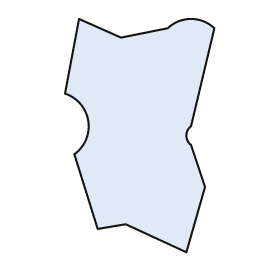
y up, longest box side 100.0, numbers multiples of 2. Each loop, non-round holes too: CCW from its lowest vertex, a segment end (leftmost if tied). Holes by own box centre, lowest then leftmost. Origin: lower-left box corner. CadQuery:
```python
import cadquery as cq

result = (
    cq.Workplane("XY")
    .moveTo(52.0, 0.0)
    .lineTo(60.0, 28.0)
    .lineTo(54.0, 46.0)
    .threePointArc((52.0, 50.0), (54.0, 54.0))
    .lineTo(64.0, 96.0)
    .threePointArc((54.0, 100.0), (44.0, 96.0))
    .lineTo(24.0, 92.0)
    .lineTo(6.0, 100.0)
    .lineTo(0.0, 68.0)
    .threePointArc((10.0, 56.0), (4.0, 42.0))
    .lineTo(14.0, 10.0)
    .lineTo(26.0, 12.0)
    .close()
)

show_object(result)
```